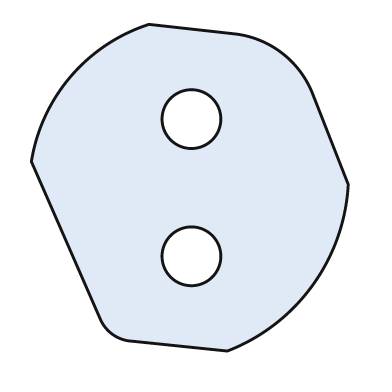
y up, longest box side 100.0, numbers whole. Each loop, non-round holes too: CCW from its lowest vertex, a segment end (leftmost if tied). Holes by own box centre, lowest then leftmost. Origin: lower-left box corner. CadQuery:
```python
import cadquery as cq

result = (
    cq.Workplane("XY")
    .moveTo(60.0, 0.0)
    .threePointArc((86.0, 20.0), (97.0, 51.0))
    .lineTo(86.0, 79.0)
    .threePointArc((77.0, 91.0), (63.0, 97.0))
    .lineTo(36.0, 100.0)
    .threePointArc((12.0, 84.0), (0.0, 58.0))
    .lineTo(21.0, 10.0)
    .threePointArc((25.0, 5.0), (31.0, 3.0))
    .close()
    .moveTo(49.0, 29.0)
    .circle(9.0)
    .moveTo(49.0, 71.0)
    .circle(9.0)
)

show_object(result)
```